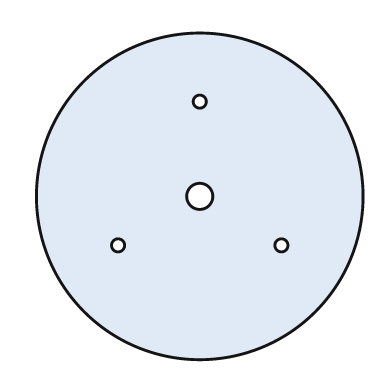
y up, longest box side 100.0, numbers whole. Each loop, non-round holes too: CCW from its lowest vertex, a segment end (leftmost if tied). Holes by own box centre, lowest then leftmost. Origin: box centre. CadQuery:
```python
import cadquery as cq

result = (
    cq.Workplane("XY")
    .moveTo(0.0, 0.0)
    .circle(50.0)
    .moveTo(-25.0, -15.0)
    .circle(2.0)
    .moveTo(25.0, -15.0)
    .circle(2.0)
    .moveTo(0.0, 0.0)
    .circle(4.0)
    .moveTo(0.0, 29.0)
    .circle(2.0)
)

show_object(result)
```